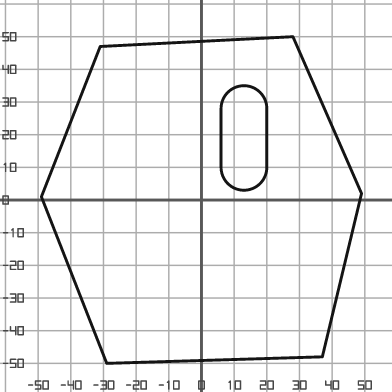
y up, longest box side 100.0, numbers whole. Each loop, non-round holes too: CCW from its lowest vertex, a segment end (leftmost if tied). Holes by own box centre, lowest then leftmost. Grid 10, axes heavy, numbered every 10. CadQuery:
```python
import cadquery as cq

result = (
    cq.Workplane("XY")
    .moveTo(-29.0, -50.0)
    .lineTo(37.0, -48.0)
    .lineTo(49.0, 2.0)
    .lineTo(28.0, 50.0)
    .lineTo(-31.0, 47.0)
    .lineTo(-49.0, 1.0)
    .close()
    .moveTo(6.0, 10.0)
    .threePointArc((13.0, 3.0), (20.0, 10.0))
    .lineTo(20.0, 28.0)
    .threePointArc((13.0, 35.0), (6.0, 28.0))
    .close()
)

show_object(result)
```